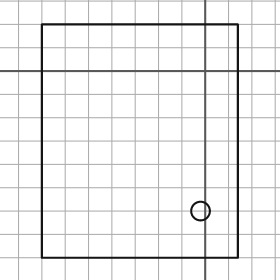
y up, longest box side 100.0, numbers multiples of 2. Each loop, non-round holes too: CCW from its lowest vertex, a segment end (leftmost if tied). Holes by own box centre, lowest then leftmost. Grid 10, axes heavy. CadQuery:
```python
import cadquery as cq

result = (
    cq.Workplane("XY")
    .moveTo(-70.0, -80.0)
    .lineTo(14.0, -80.0)
    .lineTo(14.0, 20.0)
    .lineTo(-70.0, 20.0)
    .close()
    .moveTo(-2.0, -60.0)
    .circle(4.0)
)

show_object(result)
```